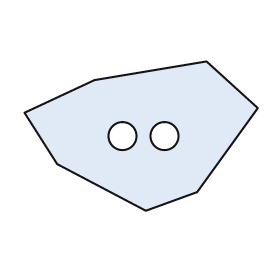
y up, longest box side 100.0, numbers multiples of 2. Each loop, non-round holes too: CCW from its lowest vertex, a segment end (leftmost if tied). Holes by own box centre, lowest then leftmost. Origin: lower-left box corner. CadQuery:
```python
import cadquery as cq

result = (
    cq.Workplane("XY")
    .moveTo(52.0, 0.0)
    .lineTo(74.0, 8.0)
    .lineTo(100.0, 44.0)
    .lineTo(78.0, 64.0)
    .lineTo(30.0, 56.0)
    .lineTo(0.0, 42.0)
    .lineTo(14.0, 20.0)
    .close()
    .moveTo(42.0, 32.0)
    .circle(6.0)
    .moveTo(60.0, 32.0)
    .circle(6.0)
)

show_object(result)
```